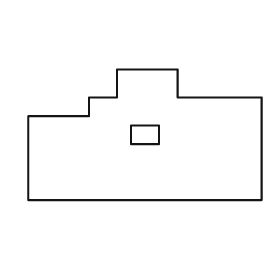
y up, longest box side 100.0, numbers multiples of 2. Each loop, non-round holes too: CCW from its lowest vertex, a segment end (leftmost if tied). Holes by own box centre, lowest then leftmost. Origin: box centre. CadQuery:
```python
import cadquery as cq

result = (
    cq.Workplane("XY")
    .moveTo(-50.0, -28.0)
    .lineTo(50.0, -28.0)
    .lineTo(50.0, 16.0)
    .lineTo(14.0, 16.0)
    .lineTo(14.0, 28.0)
    .lineTo(-12.0, 28.0)
    .lineTo(-12.0, 16.0)
    .lineTo(-24.0, 16.0)
    .lineTo(-24.0, 8.0)
    .lineTo(-50.0, 8.0)
    .close()
    .moveTo(-6.0, -4.0)
    .lineTo(6.0, -4.0)
    .lineTo(6.0, 4.0)
    .lineTo(-6.0, 4.0)
    .close()
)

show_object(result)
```